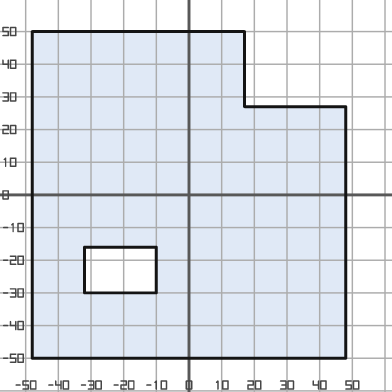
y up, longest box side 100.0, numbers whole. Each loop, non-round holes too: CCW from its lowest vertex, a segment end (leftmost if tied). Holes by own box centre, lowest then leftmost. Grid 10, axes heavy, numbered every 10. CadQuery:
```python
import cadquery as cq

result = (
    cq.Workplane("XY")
    .moveTo(-48.0, -50.0)
    .lineTo(48.0, -50.0)
    .lineTo(48.0, 27.0)
    .lineTo(17.0, 27.0)
    .lineTo(17.0, 50.0)
    .lineTo(-48.0, 50.0)
    .close()
    .moveTo(-32.0, -30.0)
    .lineTo(-10.0, -30.0)
    .lineTo(-10.0, -16.0)
    .lineTo(-32.0, -16.0)
    .close()
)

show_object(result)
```